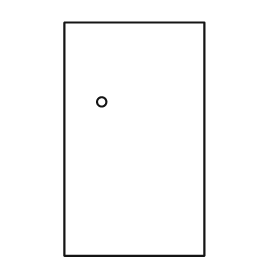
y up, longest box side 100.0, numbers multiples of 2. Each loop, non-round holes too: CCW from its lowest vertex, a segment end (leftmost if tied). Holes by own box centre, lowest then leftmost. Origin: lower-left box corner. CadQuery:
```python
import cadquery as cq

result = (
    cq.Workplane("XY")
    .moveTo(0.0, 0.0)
    .lineTo(60.0, 0.0)
    .lineTo(60.0, 100.0)
    .lineTo(0.0, 100.0)
    .close()
    .moveTo(16.0, 66.0)
    .circle(2.0)
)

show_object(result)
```